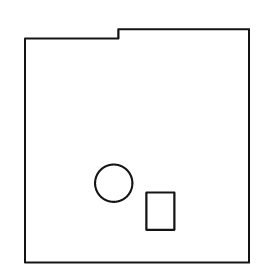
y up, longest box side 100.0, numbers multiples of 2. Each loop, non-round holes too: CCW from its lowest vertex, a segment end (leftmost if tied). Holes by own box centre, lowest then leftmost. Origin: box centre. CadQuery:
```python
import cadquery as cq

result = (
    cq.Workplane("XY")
    .moveTo(-48.0, -50.0)
    .lineTo(48.0, -50.0)
    .lineTo(48.0, 50.0)
    .lineTo(-8.0, 50.0)
    .lineTo(-8.0, 46.0)
    .lineTo(-48.0, 46.0)
    .close()
    .moveTo(4.0, -36.0)
    .lineTo(16.0, -36.0)
    .lineTo(16.0, -20.0)
    .lineTo(4.0, -20.0)
    .close()
    .moveTo(-10.0, -16.0)
    .circle(8.0)
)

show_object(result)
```